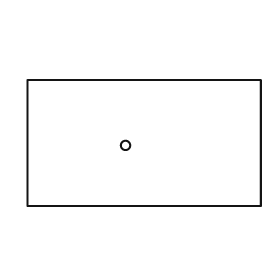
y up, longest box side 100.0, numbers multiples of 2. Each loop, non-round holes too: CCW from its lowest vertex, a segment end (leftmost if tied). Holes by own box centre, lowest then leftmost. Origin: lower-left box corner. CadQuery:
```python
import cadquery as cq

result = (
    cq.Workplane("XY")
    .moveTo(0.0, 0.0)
    .lineTo(100.0, 0.0)
    .lineTo(100.0, 54.0)
    .lineTo(0.0, 54.0)
    .close()
    .moveTo(42.0, 26.0)
    .circle(2.0)
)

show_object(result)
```